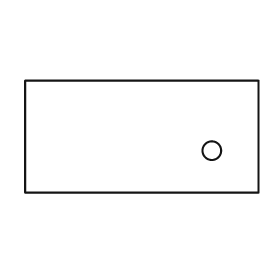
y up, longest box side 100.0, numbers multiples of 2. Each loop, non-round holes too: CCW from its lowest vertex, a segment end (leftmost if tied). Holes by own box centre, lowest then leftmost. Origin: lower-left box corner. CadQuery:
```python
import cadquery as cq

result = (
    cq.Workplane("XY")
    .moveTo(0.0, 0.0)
    .lineTo(100.0, 0.0)
    .lineTo(100.0, 48.0)
    .lineTo(0.0, 48.0)
    .close()
    .moveTo(80.0, 18.0)
    .circle(4.0)
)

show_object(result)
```